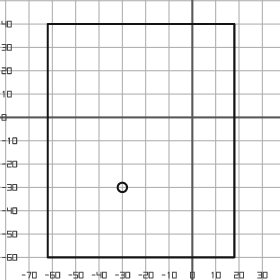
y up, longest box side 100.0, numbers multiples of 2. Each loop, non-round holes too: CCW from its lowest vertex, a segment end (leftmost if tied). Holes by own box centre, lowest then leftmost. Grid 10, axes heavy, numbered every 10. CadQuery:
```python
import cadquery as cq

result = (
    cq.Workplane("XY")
    .moveTo(-62.0, -60.0)
    .lineTo(18.0, -60.0)
    .lineTo(18.0, 40.0)
    .lineTo(-62.0, 40.0)
    .close()
    .moveTo(-30.0, -30.0)
    .circle(2.0)
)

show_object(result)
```